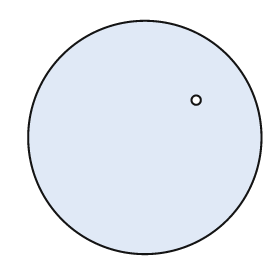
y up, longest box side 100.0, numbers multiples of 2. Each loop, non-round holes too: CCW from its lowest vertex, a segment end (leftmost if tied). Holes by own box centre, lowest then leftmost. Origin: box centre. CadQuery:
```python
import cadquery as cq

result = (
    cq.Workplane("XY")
    .moveTo(0.0, 0.0)
    .circle(50.0)
    .moveTo(22.0, 16.0)
    .circle(2.0)
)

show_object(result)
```